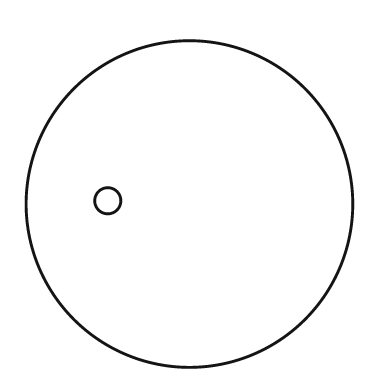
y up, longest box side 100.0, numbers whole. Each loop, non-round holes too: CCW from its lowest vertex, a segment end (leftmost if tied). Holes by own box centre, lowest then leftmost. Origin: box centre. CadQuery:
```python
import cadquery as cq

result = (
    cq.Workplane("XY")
    .moveTo(0.0, 0.0)
    .circle(50.0)
    .moveTo(-25.0, 1.0)
    .circle(4.0)
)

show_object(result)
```